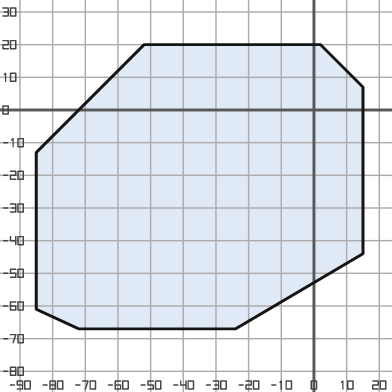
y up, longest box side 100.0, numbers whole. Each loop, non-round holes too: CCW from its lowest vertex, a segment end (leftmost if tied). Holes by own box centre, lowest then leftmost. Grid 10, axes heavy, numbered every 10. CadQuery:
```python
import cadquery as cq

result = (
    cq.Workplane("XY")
    .moveTo(-72.0, -67.0)
    .lineTo(-24.0, -67.0)
    .lineTo(15.0, -44.0)
    .lineTo(15.0, 7.0)
    .lineTo(2.0, 20.0)
    .lineTo(-52.0, 20.0)
    .lineTo(-85.0, -13.0)
    .lineTo(-85.0, -61.0)
    .close()
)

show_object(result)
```